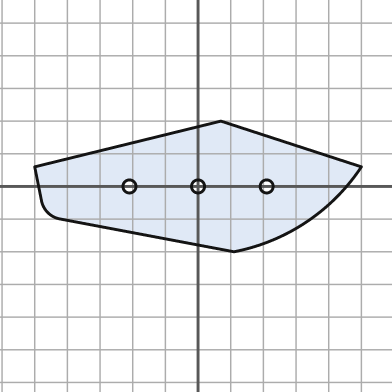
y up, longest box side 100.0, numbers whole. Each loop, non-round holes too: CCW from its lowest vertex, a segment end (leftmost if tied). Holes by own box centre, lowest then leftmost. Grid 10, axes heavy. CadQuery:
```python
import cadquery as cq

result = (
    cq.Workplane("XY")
    .moveTo(11.0, -20.0)
    .threePointArc((33.0, -11.0), (50.0, 6.0))
    .lineTo(7.0, 20.0)
    .lineTo(-50.0, 6.0)
    .lineTo(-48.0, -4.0)
    .threePointArc((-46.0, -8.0), (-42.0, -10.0))
    .close()
    .moveTo(-21.0, 0.0)
    .circle(2.0)
    .moveTo(0.0, 0.0)
    .circle(2.0)
    .moveTo(21.0, 0.0)
    .circle(2.0)
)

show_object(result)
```